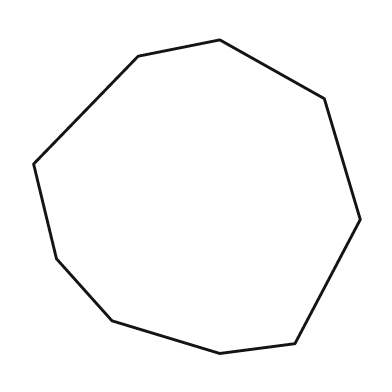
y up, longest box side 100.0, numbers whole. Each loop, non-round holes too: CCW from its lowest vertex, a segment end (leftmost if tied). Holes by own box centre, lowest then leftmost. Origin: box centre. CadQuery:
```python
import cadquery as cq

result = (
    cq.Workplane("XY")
    .moveTo(7.0, -48.0)
    .lineTo(30.0, -45.0)
    .lineTo(50.0, -7.0)
    .lineTo(39.0, 30.0)
    .lineTo(7.0, 48.0)
    .lineTo(-18.0, 43.0)
    .lineTo(-50.0, 10.0)
    .lineTo(-43.0, -19.0)
    .lineTo(-26.0, -38.0)
    .close()
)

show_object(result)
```